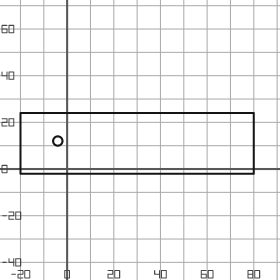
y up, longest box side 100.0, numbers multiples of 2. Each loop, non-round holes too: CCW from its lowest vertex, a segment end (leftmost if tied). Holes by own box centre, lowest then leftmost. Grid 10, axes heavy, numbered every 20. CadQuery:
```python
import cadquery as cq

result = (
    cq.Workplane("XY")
    .moveTo(-20.0, -2.0)
    .lineTo(80.0, -2.0)
    .lineTo(80.0, 24.0)
    .lineTo(-20.0, 24.0)
    .close()
    .moveTo(-4.0, 12.0)
    .circle(2.0)
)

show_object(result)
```